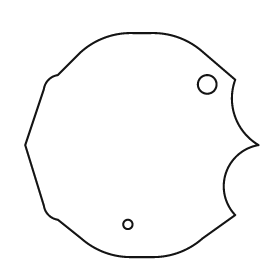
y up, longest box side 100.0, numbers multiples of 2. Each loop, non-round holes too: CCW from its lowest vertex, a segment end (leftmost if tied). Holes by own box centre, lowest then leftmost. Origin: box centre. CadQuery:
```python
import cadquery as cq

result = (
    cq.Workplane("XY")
    .moveTo(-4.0, -48.0)
    .lineTo(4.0, -48.0)
    .threePointArc((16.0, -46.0), (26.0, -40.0))
    .lineTo(40.0, -30.0)
    .threePointArc((36.0, -12.0), (50.0, 0.0))
    .threePointArc((40.0, 12.0), (40.0, 28.0))
    .lineTo(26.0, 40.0)
    .threePointArc((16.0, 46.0), (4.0, 48.0))
    .lineTo(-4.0, 48.0)
    .threePointArc((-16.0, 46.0), (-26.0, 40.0))
    .lineTo(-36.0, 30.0)
    .threePointArc((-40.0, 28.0), (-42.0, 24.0))
    .lineTo(-50.0, 0.0)
    .lineTo(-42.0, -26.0)
    .threePointArc((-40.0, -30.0), (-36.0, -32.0))
    .lineTo(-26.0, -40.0)
    .threePointArc((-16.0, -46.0), (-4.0, -48.0))
    .close()
    .moveTo(-6.0, -34.0)
    .circle(2.0)
    .moveTo(28.0, 26.0)
    .circle(4.0)
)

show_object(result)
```